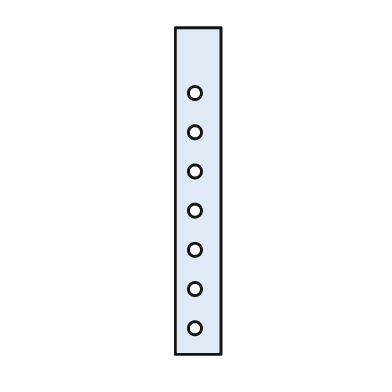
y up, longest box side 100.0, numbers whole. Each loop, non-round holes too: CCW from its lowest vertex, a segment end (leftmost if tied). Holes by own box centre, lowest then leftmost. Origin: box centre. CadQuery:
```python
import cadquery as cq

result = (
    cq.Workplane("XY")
    .moveTo(-7.0, -50.0)
    .lineTo(7.0, -50.0)
    .lineTo(7.0, 50.0)
    .lineTo(-7.0, 50.0)
    .close()
    .moveTo(-1.0, -42.0)
    .circle(2.0)
    .moveTo(-1.0, -30.0)
    .circle(2.0)
    .moveTo(-1.0, -18.0)
    .circle(2.0)
    .moveTo(-1.0, -6.0)
    .circle(2.0)
    .moveTo(-1.0, 6.0)
    .circle(2.0)
    .moveTo(-1.0, 18.0)
    .circle(2.0)
    .moveTo(-1.0, 30.0)
    .circle(2.0)
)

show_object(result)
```